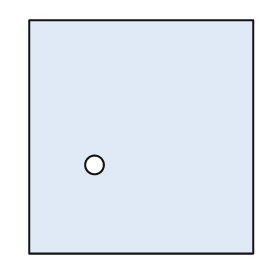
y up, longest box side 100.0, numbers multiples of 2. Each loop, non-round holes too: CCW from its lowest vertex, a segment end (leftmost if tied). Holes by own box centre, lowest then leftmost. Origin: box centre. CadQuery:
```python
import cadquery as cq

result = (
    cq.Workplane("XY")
    .moveTo(-48.0, -50.0)
    .lineTo(48.0, -50.0)
    .lineTo(48.0, 50.0)
    .lineTo(-48.0, 50.0)
    .close()
    .moveTo(-20.0, -12.0)
    .circle(4.0)
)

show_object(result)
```